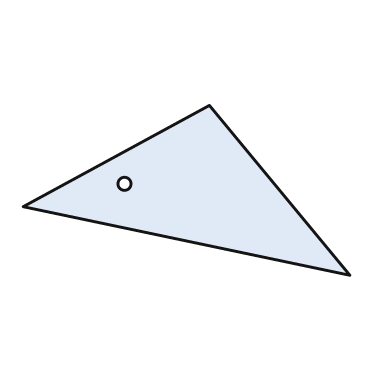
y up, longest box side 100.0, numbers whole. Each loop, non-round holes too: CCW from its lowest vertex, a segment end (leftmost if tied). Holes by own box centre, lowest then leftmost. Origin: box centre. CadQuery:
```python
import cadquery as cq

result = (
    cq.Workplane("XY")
    .moveTo(50.0, -26.0)
    .lineTo(7.0, 26.0)
    .lineTo(-50.0, -5.0)
    .close()
    .moveTo(-19.0, 2.0)
    .circle(2.0)
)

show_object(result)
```